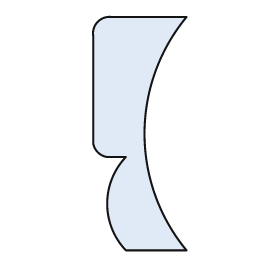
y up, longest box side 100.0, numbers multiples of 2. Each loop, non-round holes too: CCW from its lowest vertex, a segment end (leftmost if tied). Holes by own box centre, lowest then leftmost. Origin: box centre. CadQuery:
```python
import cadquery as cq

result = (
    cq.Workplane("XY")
    .moveTo(-6.0, -50.0)
    .lineTo(20.0, -50.0)
    .threePointArc((2.0, 0.0), (20.0, 50.0))
    .lineTo(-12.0, 50.0)
    .threePointArc((-18.0, 48.0), (-20.0, 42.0))
    .lineTo(-20.0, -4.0)
    .threePointArc((-18.0, -8.0), (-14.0, -10.0))
    .lineTo(-6.0, -10.0)
    .threePointArc((-14.0, -30.0), (-6.0, -50.0))
    .close()
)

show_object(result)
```